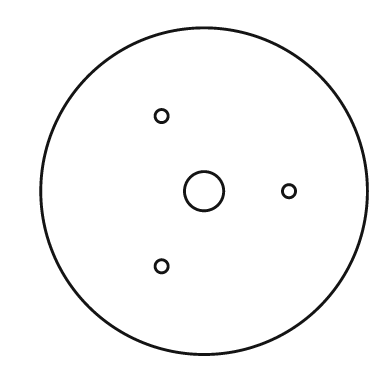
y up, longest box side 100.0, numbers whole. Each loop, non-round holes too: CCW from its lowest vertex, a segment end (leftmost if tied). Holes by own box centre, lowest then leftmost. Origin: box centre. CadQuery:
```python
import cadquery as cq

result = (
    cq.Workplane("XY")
    .moveTo(0.0, 0.0)
    .circle(50.0)
    .moveTo(-13.0, -23.0)
    .circle(2.0)
    .moveTo(0.0, 0.0)
    .circle(6.0)
    .moveTo(26.0, 0.0)
    .circle(2.0)
    .moveTo(-13.0, 23.0)
    .circle(2.0)
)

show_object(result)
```